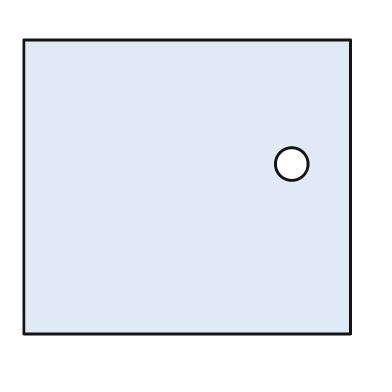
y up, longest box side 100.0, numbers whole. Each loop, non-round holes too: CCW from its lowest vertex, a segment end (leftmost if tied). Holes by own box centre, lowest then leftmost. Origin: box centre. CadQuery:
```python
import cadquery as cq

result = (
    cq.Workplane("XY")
    .moveTo(-50.0, -45.0)
    .lineTo(50.0, -45.0)
    .lineTo(50.0, 45.0)
    .lineTo(-50.0, 45.0)
    .close()
    .moveTo(32.0, 7.0)
    .circle(5.0)
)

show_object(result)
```